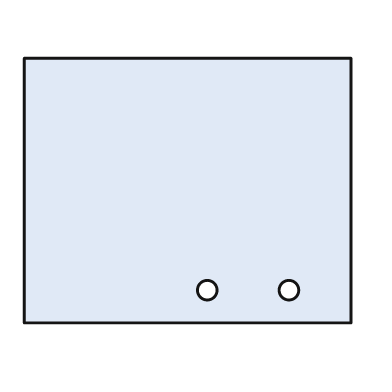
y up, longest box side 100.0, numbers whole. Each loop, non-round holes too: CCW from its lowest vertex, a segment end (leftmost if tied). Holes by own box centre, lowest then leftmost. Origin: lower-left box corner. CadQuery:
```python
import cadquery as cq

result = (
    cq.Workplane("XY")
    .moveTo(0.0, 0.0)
    .lineTo(100.0, 0.0)
    .lineTo(100.0, 81.0)
    .lineTo(0.0, 81.0)
    .close()
    .moveTo(56.0, 10.0)
    .circle(3.0)
    .moveTo(81.0, 10.0)
    .circle(3.0)
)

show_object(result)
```